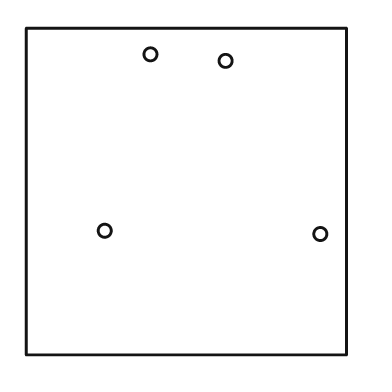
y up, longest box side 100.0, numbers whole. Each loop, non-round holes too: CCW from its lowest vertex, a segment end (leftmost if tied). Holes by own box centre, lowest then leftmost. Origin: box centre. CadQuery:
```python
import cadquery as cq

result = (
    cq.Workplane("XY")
    .moveTo(-49.0, -50.0)
    .lineTo(49.0, -50.0)
    .lineTo(49.0, 50.0)
    .lineTo(-49.0, 50.0)
    .close()
    .moveTo(41.0, -13.0)
    .circle(2.0)
    .moveTo(-25.0, -12.0)
    .circle(2.0)
    .moveTo(12.0, 40.0)
    .circle(2.0)
    .moveTo(-11.0, 42.0)
    .circle(2.0)
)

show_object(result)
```